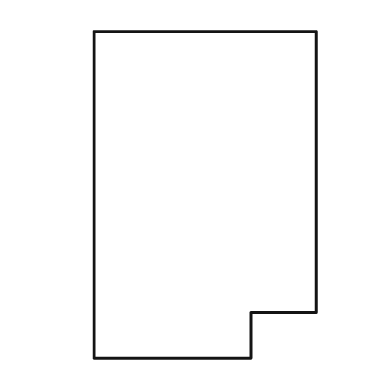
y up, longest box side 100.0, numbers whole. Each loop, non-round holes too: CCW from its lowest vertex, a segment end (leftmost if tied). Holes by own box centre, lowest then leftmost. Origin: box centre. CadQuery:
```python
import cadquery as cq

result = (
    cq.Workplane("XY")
    .moveTo(-34.0, -50.0)
    .lineTo(14.0, -50.0)
    .lineTo(14.0, -36.0)
    .lineTo(34.0, -36.0)
    .lineTo(34.0, 50.0)
    .lineTo(-34.0, 50.0)
    .close()
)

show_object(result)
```